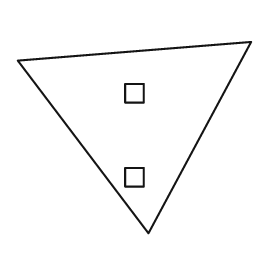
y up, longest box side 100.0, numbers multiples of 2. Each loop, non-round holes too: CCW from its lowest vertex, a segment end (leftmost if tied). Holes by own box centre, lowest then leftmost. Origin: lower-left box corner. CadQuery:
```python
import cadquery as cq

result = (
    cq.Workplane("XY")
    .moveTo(56.0, 0.0)
    .lineTo(100.0, 82.0)
    .lineTo(0.0, 74.0)
    .close()
    .moveTo(46.0, 20.0)
    .lineTo(54.0, 20.0)
    .lineTo(54.0, 28.0)
    .lineTo(46.0, 28.0)
    .close()
    .moveTo(46.0, 56.0)
    .lineTo(54.0, 56.0)
    .lineTo(54.0, 64.0)
    .lineTo(46.0, 64.0)
    .close()
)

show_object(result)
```